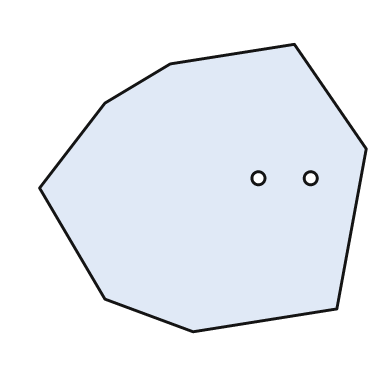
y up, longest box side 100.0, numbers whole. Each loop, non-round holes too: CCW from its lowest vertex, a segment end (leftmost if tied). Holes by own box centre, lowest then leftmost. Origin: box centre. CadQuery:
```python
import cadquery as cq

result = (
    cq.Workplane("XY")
    .moveTo(-3.0, -44.0)
    .lineTo(41.0, -37.0)
    .lineTo(50.0, 12.0)
    .lineTo(28.0, 44.0)
    .lineTo(-10.0, 38.0)
    .lineTo(-30.0, 26.0)
    .lineTo(-50.0, 0.0)
    .lineTo(-30.0, -34.0)
    .close()
    .moveTo(17.0, 3.0)
    .circle(2.0)
    .moveTo(33.0, 3.0)
    .circle(2.0)
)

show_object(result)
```